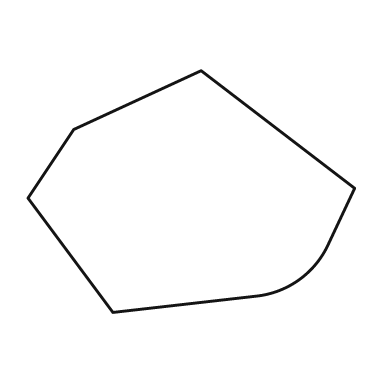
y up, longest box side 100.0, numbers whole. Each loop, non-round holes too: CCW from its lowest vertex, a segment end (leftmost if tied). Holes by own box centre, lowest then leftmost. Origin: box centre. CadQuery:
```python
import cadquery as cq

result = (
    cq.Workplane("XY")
    .moveTo(-24.0, -37.0)
    .lineTo(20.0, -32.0)
    .threePointArc((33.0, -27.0), (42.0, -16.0))
    .lineTo(50.0, 1.0)
    .lineTo(3.0, 37.0)
    .lineTo(-36.0, 19.0)
    .lineTo(-50.0, -2.0)
    .close()
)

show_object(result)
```